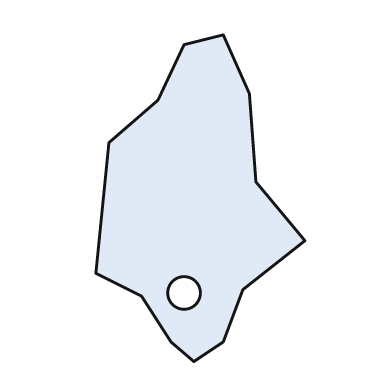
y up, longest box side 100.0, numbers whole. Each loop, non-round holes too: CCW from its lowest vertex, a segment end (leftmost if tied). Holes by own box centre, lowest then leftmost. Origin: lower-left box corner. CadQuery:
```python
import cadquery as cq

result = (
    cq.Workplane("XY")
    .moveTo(30.0, 0.0)
    .lineTo(39.0, 6.0)
    .lineTo(45.0, 22.0)
    .lineTo(64.0, 37.0)
    .lineTo(49.0, 55.0)
    .lineTo(47.0, 82.0)
    .lineTo(39.0, 100.0)
    .lineTo(27.0, 97.0)
    .lineTo(19.0, 80.0)
    .lineTo(4.0, 67.0)
    .lineTo(0.0, 27.0)
    .lineTo(14.0, 20.0)
    .lineTo(23.0, 6.0)
    .close()
    .moveTo(27.0, 21.0)
    .circle(5.0)
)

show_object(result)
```